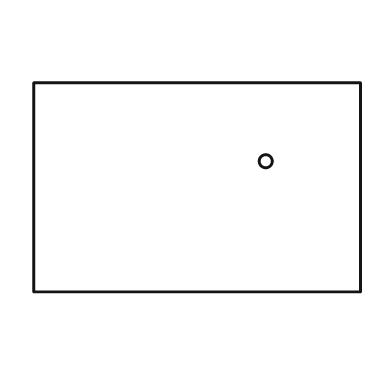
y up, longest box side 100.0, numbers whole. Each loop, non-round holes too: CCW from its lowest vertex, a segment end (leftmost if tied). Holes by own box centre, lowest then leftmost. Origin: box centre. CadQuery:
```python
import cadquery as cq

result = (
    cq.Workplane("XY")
    .moveTo(-50.0, -32.0)
    .lineTo(50.0, -32.0)
    .lineTo(50.0, 32.0)
    .lineTo(-50.0, 32.0)
    .close()
    .moveTo(21.0, 8.0)
    .circle(2.0)
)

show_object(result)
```